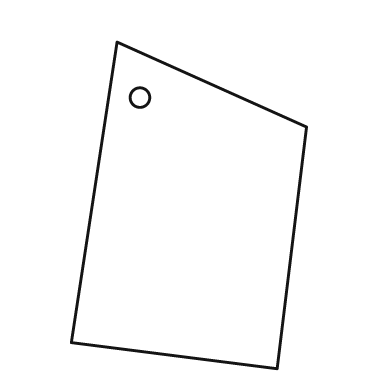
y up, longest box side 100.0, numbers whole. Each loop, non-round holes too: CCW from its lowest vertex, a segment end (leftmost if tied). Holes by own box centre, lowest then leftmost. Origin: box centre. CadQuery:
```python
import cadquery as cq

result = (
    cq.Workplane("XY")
    .moveTo(27.0, -50.0)
    .lineTo(36.0, 24.0)
    .lineTo(-22.0, 50.0)
    .lineTo(-36.0, -42.0)
    .close()
    .moveTo(-15.0, 33.0)
    .circle(3.0)
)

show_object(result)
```